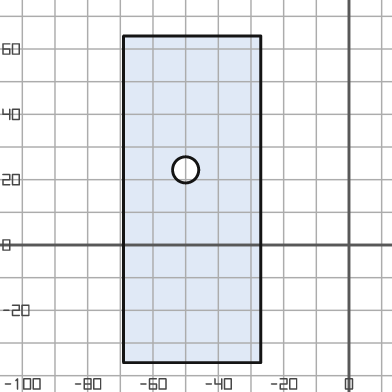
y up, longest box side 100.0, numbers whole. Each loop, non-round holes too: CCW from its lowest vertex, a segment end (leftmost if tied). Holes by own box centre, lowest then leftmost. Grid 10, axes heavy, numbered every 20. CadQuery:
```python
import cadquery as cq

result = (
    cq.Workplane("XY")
    .moveTo(-69.0, -36.0)
    .lineTo(-27.0, -36.0)
    .lineTo(-27.0, 64.0)
    .lineTo(-69.0, 64.0)
    .close()
    .moveTo(-50.0, 23.0)
    .circle(4.0)
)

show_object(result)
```